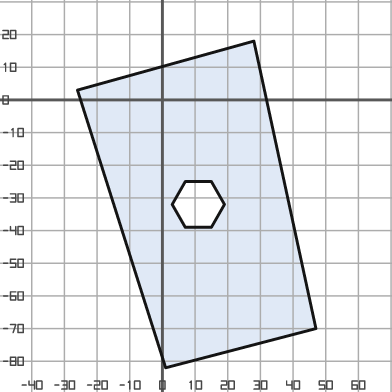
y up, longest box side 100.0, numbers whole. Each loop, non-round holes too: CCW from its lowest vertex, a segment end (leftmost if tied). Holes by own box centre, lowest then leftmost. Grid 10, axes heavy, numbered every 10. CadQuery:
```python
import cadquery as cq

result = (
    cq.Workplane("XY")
    .moveTo(1.0, -82.0)
    .lineTo(47.0, -70.0)
    .lineTo(28.0, 18.0)
    .lineTo(-26.0, 3.0)
    .close()
    .moveTo(7.0, -39.0)
    .lineTo(15.0, -39.0)
    .lineTo(19.0, -32.0)
    .lineTo(15.0, -25.0)
    .lineTo(7.0, -25.0)
    .lineTo(3.0, -32.0)
    .close()
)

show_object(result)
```